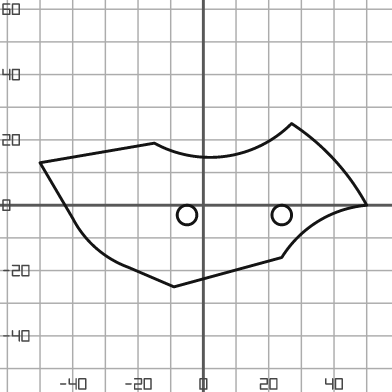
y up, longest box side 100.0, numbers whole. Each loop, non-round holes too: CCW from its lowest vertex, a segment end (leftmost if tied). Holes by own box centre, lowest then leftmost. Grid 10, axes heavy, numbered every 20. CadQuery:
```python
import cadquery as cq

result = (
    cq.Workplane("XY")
    .moveTo(-9.0, -25.0)
    .lineTo(24.0, -16.0)
    .threePointArc((35.0, -5.0), (50.0, 0.0))
    .threePointArc((40.0, 14.0), (27.0, 25.0))
    .threePointArc((7.0, 15.0), (-15.0, 19.0))
    .lineTo(-50.0, 13.0)
    .lineTo(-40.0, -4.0)
    .threePointArc((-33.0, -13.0), (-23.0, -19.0))
    .close()
    .moveTo(-5.0, -3.0)
    .circle(3.0)
    .moveTo(24.0, -3.0)
    .circle(3.0)
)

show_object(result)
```